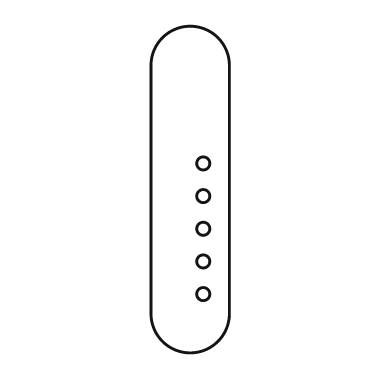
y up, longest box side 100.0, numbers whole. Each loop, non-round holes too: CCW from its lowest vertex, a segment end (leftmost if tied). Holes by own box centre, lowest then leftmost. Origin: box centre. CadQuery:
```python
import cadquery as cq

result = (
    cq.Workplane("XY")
    .moveTo(-12.0, -38.0)
    .threePointArc((0.0, -50.0), (12.0, -38.0))
    .lineTo(12.0, 38.0)
    .threePointArc((0.0, 50.0), (-12.0, 38.0))
    .close()
    .moveTo(4.0, -32.0)
    .circle(2.0)
    .moveTo(4.0, -22.0)
    .circle(2.0)
    .moveTo(4.0, -12.0)
    .circle(2.0)
    .moveTo(4.0, -2.0)
    .circle(2.0)
    .moveTo(4.0, 8.0)
    .circle(2.0)
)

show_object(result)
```